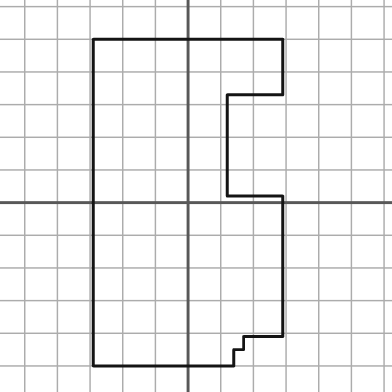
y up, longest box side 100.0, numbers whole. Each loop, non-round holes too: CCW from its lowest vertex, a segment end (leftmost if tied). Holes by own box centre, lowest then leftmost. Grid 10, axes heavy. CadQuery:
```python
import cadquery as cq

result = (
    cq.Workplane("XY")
    .moveTo(-29.0, -50.0)
    .lineTo(14.0, -50.0)
    .lineTo(14.0, -45.0)
    .lineTo(17.0, -45.0)
    .lineTo(17.0, -41.0)
    .lineTo(29.0, -41.0)
    .lineTo(29.0, 2.0)
    .lineTo(12.0, 2.0)
    .lineTo(12.0, 33.0)
    .lineTo(29.0, 33.0)
    .lineTo(29.0, 50.0)
    .lineTo(-29.0, 50.0)
    .close()
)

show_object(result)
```